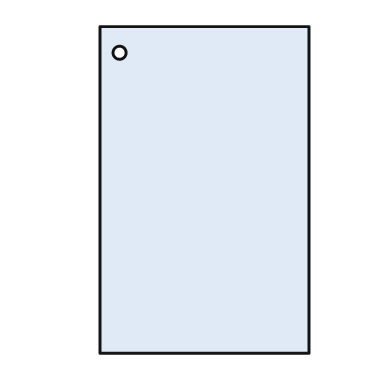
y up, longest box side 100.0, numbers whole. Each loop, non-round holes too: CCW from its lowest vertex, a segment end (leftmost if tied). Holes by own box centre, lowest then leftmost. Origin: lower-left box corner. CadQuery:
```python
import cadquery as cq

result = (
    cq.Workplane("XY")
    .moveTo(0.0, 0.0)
    .lineTo(64.0, 0.0)
    .lineTo(64.0, 100.0)
    .lineTo(0.0, 100.0)
    .close()
    .moveTo(6.0, 92.0)
    .circle(2.0)
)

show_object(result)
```